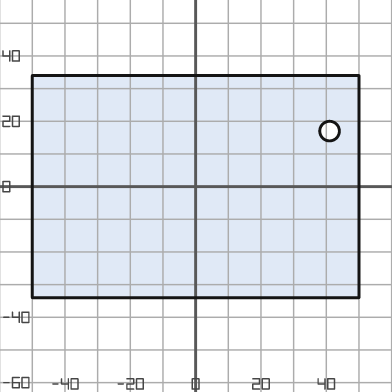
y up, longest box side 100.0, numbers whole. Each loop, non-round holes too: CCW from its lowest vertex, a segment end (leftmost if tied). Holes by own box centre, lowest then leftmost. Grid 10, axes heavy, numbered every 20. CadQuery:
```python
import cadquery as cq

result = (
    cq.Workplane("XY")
    .moveTo(-50.0, -34.0)
    .lineTo(50.0, -34.0)
    .lineTo(50.0, 34.0)
    .lineTo(-50.0, 34.0)
    .close()
    .moveTo(41.0, 17.0)
    .circle(3.0)
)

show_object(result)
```